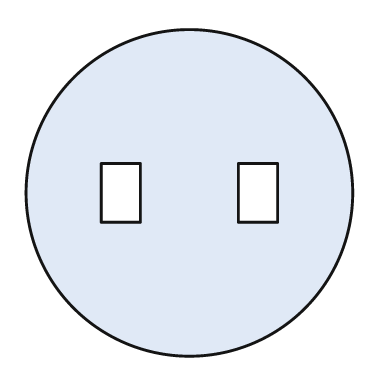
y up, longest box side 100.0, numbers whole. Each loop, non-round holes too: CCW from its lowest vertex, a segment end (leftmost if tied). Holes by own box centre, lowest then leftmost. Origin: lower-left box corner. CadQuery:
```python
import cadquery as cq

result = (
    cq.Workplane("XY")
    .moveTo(50.0, 50.0)
    .circle(50.0)
    .moveTo(23.0, 41.0)
    .lineTo(35.0, 41.0)
    .lineTo(35.0, 59.0)
    .lineTo(23.0, 59.0)
    .close()
    .moveTo(65.0, 41.0)
    .lineTo(77.0, 41.0)
    .lineTo(77.0, 59.0)
    .lineTo(65.0, 59.0)
    .close()
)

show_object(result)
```